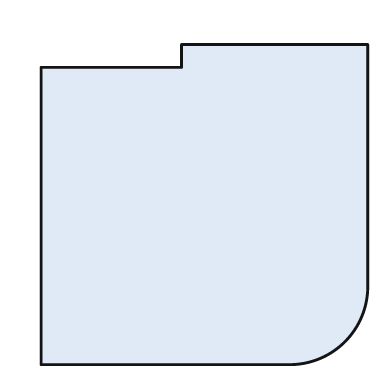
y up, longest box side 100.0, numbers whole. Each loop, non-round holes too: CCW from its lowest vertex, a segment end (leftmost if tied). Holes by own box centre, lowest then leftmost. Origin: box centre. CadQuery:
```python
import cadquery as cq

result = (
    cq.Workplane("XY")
    .moveTo(-50.0, -49.0)
    .lineTo(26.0, -49.0)
    .threePointArc((43.0, -42.0), (50.0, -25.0))
    .lineTo(50.0, 49.0)
    .lineTo(-7.0, 49.0)
    .lineTo(-7.0, 42.0)
    .lineTo(-50.0, 42.0)
    .close()
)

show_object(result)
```